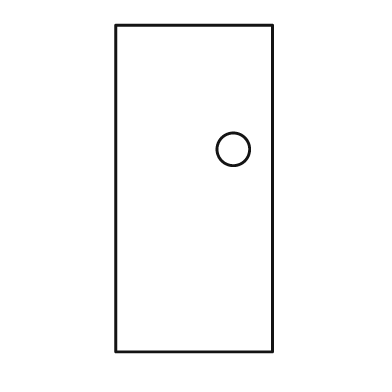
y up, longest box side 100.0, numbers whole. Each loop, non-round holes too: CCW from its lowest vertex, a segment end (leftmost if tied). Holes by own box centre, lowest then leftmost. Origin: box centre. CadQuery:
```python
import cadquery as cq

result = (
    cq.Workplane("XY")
    .moveTo(-24.0, -50.0)
    .lineTo(24.0, -50.0)
    .lineTo(24.0, 50.0)
    .lineTo(-24.0, 50.0)
    .close()
    .moveTo(12.0, 12.0)
    .circle(5.0)
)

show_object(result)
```